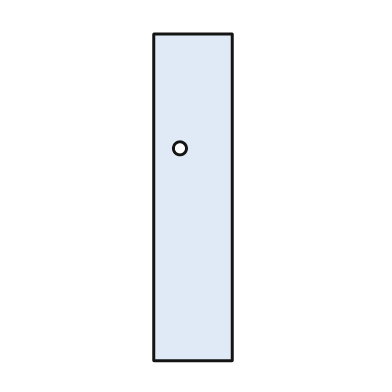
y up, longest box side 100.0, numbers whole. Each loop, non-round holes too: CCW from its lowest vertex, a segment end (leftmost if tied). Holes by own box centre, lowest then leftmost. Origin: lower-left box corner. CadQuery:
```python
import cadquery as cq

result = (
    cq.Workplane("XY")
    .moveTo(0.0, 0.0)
    .lineTo(24.0, 0.0)
    .lineTo(24.0, 100.0)
    .lineTo(0.0, 100.0)
    .close()
    .moveTo(8.0, 65.0)
    .circle(2.0)
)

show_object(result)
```